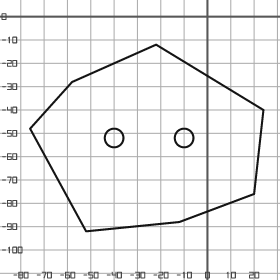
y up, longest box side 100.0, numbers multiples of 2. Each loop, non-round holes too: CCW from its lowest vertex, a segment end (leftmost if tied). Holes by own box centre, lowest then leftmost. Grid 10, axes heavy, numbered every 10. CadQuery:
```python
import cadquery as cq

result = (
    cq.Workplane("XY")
    .moveTo(-52.0, -92.0)
    .lineTo(-12.0, -88.0)
    .lineTo(20.0, -76.0)
    .lineTo(24.0, -40.0)
    .lineTo(-22.0, -12.0)
    .lineTo(-58.0, -28.0)
    .lineTo(-76.0, -48.0)
    .close()
    .moveTo(-40.0, -52.0)
    .circle(4.0)
    .moveTo(-10.0, -52.0)
    .circle(4.0)
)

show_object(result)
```